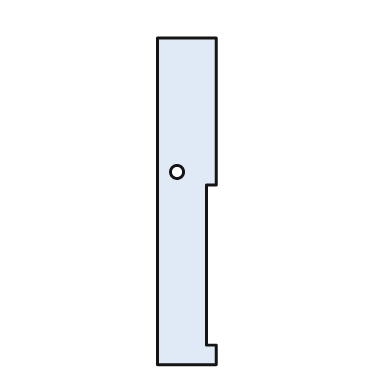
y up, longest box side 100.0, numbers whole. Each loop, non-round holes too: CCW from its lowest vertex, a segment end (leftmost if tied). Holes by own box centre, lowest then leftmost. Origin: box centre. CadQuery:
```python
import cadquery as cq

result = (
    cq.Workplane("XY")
    .moveTo(-9.0, -50.0)
    .lineTo(9.0, -50.0)
    .lineTo(9.0, -44.0)
    .lineTo(6.0, -44.0)
    .lineTo(6.0, 5.0)
    .lineTo(9.0, 5.0)
    .lineTo(9.0, 50.0)
    .lineTo(-9.0, 50.0)
    .close()
    .moveTo(-3.0, 9.0)
    .circle(2.0)
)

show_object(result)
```